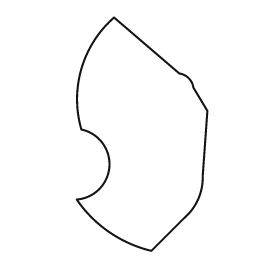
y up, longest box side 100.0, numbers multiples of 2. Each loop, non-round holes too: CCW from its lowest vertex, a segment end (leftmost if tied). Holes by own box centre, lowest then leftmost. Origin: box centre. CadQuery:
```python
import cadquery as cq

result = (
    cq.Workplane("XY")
    .moveTo(4.0, -50.0)
    .lineTo(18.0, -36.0)
    .threePointArc((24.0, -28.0), (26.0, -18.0))
    .lineTo(28.0, 10.0)
    .lineTo(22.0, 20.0)
    .threePointArc((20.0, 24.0), (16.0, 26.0))
    .lineTo(-12.0, 50.0)
    .threePointArc((-26.0, 28.0), (-26.0, 2.0))
    .threePointArc((-14.0, -14.0), (-28.0, -28.0))
    .threePointArc((-14.0, -42.0), (4.0, -50.0))
    .close()
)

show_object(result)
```